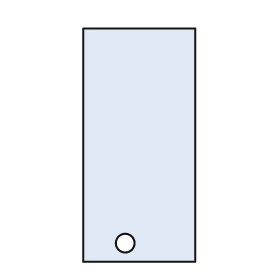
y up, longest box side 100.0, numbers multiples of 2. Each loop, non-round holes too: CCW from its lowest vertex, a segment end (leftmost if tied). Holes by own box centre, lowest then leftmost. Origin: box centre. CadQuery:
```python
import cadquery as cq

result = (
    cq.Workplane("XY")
    .moveTo(-24.0, -50.0)
    .lineTo(24.0, -50.0)
    .lineTo(24.0, 50.0)
    .lineTo(-24.0, 50.0)
    .close()
    .moveTo(-6.0, -42.0)
    .circle(4.0)
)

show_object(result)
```